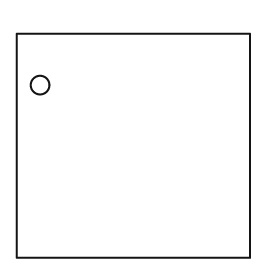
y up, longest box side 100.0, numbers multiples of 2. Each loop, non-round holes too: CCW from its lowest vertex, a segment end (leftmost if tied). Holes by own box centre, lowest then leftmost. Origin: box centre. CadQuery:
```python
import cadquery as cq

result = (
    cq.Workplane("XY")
    .moveTo(-50.0, -48.0)
    .lineTo(50.0, -48.0)
    .lineTo(50.0, 48.0)
    .lineTo(-50.0, 48.0)
    .close()
    .moveTo(-40.0, 26.0)
    .circle(4.0)
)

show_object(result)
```